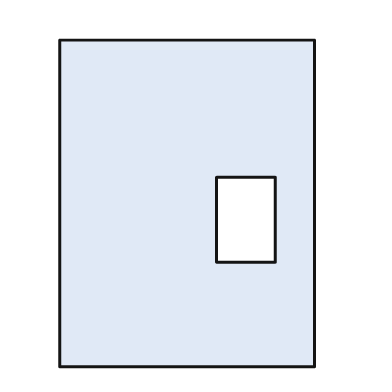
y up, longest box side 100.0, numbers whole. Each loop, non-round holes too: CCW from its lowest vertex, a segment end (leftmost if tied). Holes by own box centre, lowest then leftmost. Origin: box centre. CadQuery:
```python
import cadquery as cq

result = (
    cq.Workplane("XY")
    .moveTo(-39.0, -50.0)
    .lineTo(39.0, -50.0)
    .lineTo(39.0, 50.0)
    .lineTo(-39.0, 50.0)
    .close()
    .moveTo(9.0, -18.0)
    .lineTo(27.0, -18.0)
    .lineTo(27.0, 8.0)
    .lineTo(9.0, 8.0)
    .close()
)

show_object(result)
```